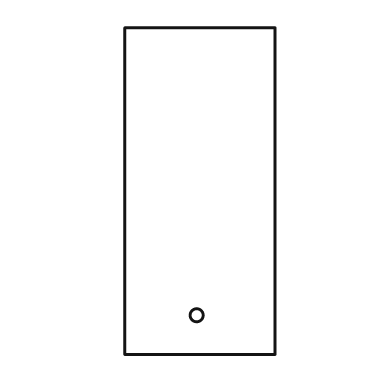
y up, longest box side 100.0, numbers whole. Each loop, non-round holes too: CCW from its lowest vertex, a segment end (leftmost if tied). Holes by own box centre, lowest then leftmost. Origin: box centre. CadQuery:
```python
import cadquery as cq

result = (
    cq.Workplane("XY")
    .moveTo(-23.0, -50.0)
    .lineTo(23.0, -50.0)
    .lineTo(23.0, 50.0)
    .lineTo(-23.0, 50.0)
    .close()
    .moveTo(-1.0, -38.0)
    .circle(2.0)
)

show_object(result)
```